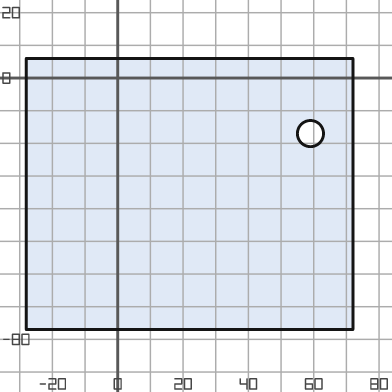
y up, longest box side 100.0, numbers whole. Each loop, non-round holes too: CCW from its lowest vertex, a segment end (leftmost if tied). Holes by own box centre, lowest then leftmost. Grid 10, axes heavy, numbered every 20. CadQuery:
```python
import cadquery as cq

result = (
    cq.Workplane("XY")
    .moveTo(-28.0, -77.0)
    .lineTo(72.0, -77.0)
    .lineTo(72.0, 6.0)
    .lineTo(-28.0, 6.0)
    .close()
    .moveTo(59.0, -17.0)
    .circle(4.0)
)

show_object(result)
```